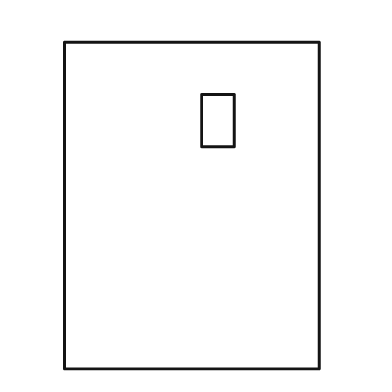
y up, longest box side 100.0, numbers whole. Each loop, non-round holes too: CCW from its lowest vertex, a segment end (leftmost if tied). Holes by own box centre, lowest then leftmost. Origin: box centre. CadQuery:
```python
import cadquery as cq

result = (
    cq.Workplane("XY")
    .moveTo(-39.0, -50.0)
    .lineTo(39.0, -50.0)
    .lineTo(39.0, 50.0)
    .lineTo(-39.0, 50.0)
    .close()
    .moveTo(3.0, 18.0)
    .lineTo(13.0, 18.0)
    .lineTo(13.0, 34.0)
    .lineTo(3.0, 34.0)
    .close()
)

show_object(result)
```